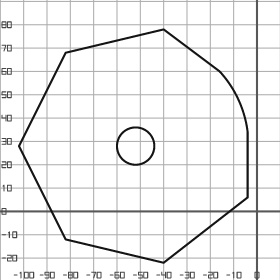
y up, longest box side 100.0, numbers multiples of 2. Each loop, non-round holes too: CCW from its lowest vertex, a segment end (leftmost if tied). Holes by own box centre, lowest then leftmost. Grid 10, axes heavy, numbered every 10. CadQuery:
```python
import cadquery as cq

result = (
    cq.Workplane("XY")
    .moveTo(-40.0, -22.0)
    .lineTo(-4.0, 6.0)
    .lineTo(-4.0, 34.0)
    .threePointArc((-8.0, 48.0), (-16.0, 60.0))
    .lineTo(-40.0, 78.0)
    .lineTo(-82.0, 68.0)
    .lineTo(-102.0, 28.0)
    .lineTo(-82.0, -12.0)
    .close()
    .moveTo(-52.0, 28.0)
    .circle(8.0)
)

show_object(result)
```